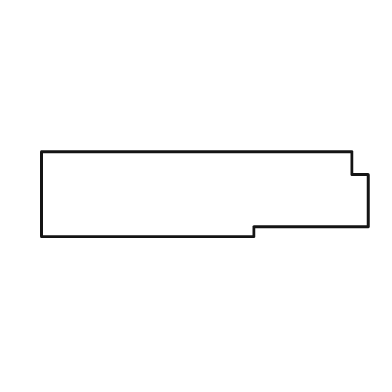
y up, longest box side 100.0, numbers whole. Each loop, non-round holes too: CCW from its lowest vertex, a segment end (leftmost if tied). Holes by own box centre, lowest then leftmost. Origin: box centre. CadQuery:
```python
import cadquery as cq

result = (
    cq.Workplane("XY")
    .moveTo(-50.0, -13.0)
    .lineTo(15.0, -13.0)
    .lineTo(15.0, -10.0)
    .lineTo(50.0, -10.0)
    .lineTo(50.0, 6.0)
    .lineTo(45.0, 6.0)
    .lineTo(45.0, 13.0)
    .lineTo(-50.0, 13.0)
    .close()
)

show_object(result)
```